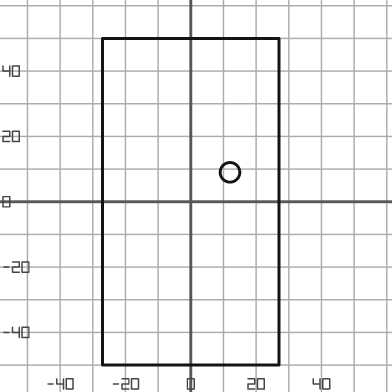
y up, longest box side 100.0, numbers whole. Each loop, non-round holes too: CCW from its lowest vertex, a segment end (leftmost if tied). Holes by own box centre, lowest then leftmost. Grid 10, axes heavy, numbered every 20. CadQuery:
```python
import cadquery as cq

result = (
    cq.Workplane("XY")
    .moveTo(-27.0, -50.0)
    .lineTo(27.0, -50.0)
    .lineTo(27.0, 50.0)
    .lineTo(-27.0, 50.0)
    .close()
    .moveTo(12.0, 9.0)
    .circle(3.0)
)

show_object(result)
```